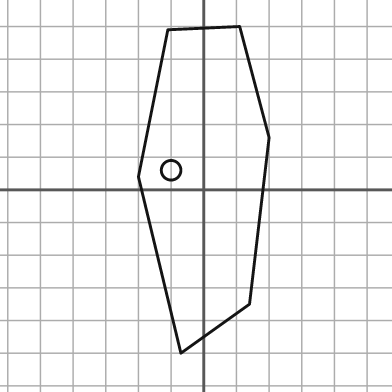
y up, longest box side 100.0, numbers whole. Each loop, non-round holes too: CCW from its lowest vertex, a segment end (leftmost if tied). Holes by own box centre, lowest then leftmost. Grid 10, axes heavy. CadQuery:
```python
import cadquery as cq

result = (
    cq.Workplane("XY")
    .moveTo(-7.0, -50.0)
    .lineTo(14.0, -35.0)
    .lineTo(20.0, 16.0)
    .lineTo(11.0, 50.0)
    .lineTo(-11.0, 49.0)
    .lineTo(-20.0, 4.0)
    .close()
    .moveTo(-10.0, 6.0)
    .circle(3.0)
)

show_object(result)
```